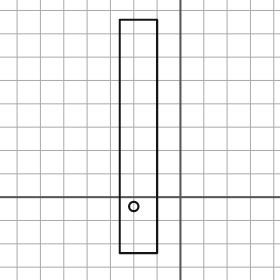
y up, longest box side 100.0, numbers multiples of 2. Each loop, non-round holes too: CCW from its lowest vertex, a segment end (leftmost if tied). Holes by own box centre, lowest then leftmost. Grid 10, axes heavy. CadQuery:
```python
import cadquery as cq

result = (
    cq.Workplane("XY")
    .moveTo(-26.0, -24.0)
    .lineTo(-10.0, -24.0)
    .lineTo(-10.0, 76.0)
    .lineTo(-26.0, 76.0)
    .close()
    .moveTo(-20.0, -4.0)
    .circle(2.0)
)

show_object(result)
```